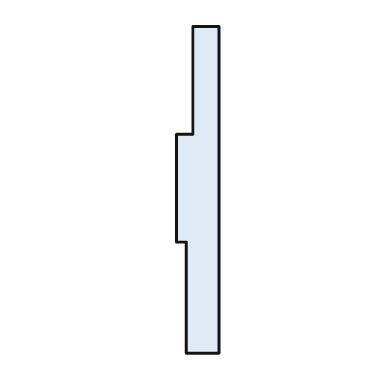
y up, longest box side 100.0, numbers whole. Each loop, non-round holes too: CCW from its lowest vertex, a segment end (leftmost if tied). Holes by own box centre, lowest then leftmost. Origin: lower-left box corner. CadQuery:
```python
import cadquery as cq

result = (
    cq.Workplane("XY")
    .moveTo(3.0, 0.0)
    .lineTo(13.0, 0.0)
    .lineTo(13.0, 100.0)
    .lineTo(5.0, 100.0)
    .lineTo(5.0, 67.0)
    .lineTo(0.0, 67.0)
    .lineTo(0.0, 34.0)
    .lineTo(3.0, 34.0)
    .close()
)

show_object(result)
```